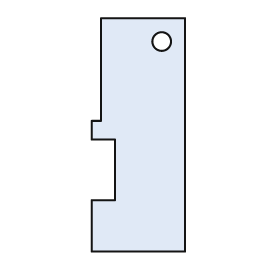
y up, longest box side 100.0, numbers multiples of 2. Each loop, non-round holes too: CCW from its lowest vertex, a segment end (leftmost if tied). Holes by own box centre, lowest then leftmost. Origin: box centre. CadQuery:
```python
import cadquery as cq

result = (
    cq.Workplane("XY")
    .moveTo(-20.0, -50.0)
    .lineTo(20.0, -50.0)
    .lineTo(20.0, 50.0)
    .lineTo(-16.0, 50.0)
    .lineTo(-16.0, 6.0)
    .lineTo(-20.0, 6.0)
    .lineTo(-20.0, -2.0)
    .lineTo(-10.0, -2.0)
    .lineTo(-10.0, -28.0)
    .lineTo(-20.0, -28.0)
    .close()
    .moveTo(10.0, 40.0)
    .circle(4.0)
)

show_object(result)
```